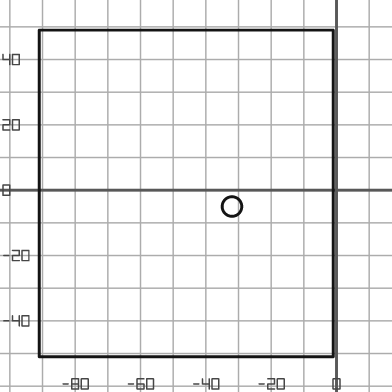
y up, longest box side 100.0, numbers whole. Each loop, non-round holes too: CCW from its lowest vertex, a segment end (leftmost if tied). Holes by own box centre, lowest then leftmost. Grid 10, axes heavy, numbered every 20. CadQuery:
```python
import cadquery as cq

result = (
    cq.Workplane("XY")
    .moveTo(-91.0, -51.0)
    .lineTo(-1.0, -51.0)
    .lineTo(-1.0, 49.0)
    .lineTo(-91.0, 49.0)
    .close()
    .moveTo(-32.0, -5.0)
    .circle(3.0)
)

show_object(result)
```